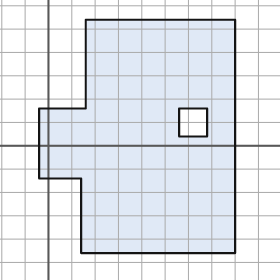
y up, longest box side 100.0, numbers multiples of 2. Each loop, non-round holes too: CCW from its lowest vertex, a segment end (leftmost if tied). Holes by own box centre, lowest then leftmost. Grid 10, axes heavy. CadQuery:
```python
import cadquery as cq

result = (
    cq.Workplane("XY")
    .moveTo(14.0, -46.0)
    .lineTo(80.0, -46.0)
    .lineTo(80.0, 54.0)
    .lineTo(16.0, 54.0)
    .lineTo(16.0, 16.0)
    .lineTo(-4.0, 16.0)
    .lineTo(-4.0, -14.0)
    .lineTo(14.0, -14.0)
    .close()
    .moveTo(56.0, 4.0)
    .lineTo(68.0, 4.0)
    .lineTo(68.0, 16.0)
    .lineTo(56.0, 16.0)
    .close()
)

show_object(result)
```